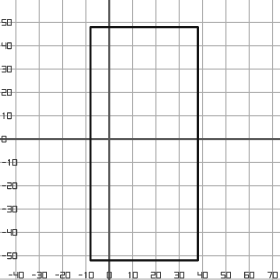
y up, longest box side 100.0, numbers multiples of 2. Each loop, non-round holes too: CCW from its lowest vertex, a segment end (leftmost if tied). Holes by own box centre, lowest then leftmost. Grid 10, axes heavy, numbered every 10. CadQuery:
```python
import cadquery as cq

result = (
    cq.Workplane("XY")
    .moveTo(-8.0, -52.0)
    .lineTo(38.0, -52.0)
    .lineTo(38.0, 48.0)
    .lineTo(-8.0, 48.0)
    .close()
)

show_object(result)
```